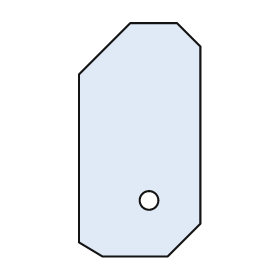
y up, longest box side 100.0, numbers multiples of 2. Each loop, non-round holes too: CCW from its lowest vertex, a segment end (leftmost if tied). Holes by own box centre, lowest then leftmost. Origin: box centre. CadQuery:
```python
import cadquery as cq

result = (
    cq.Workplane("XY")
    .moveTo(-16.0, -50.0)
    .lineTo(12.0, -50.0)
    .lineTo(26.0, -36.0)
    .lineTo(26.0, 40.0)
    .lineTo(16.0, 50.0)
    .lineTo(-4.0, 50.0)
    .lineTo(-26.0, 28.0)
    .lineTo(-26.0, -44.0)
    .close()
    .moveTo(4.0, -26.0)
    .circle(4.0)
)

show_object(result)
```